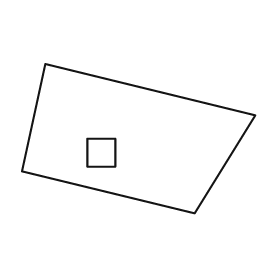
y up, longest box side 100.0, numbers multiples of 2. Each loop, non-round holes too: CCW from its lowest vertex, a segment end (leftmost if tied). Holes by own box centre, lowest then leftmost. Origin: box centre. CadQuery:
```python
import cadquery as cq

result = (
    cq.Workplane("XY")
    .moveTo(24.0, -32.0)
    .lineTo(50.0, 10.0)
    .lineTo(-40.0, 32.0)
    .lineTo(-50.0, -14.0)
    .close()
    .moveTo(-22.0, -12.0)
    .lineTo(-10.0, -12.0)
    .lineTo(-10.0, 0.0)
    .lineTo(-22.0, 0.0)
    .close()
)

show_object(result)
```